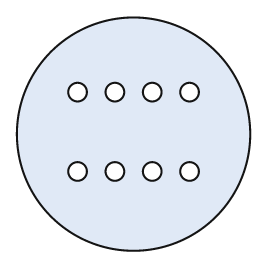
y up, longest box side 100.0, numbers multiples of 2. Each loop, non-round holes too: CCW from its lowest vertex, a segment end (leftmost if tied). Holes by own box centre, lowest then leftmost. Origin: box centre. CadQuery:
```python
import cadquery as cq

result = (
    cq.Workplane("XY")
    .moveTo(0.0, 0.0)
    .circle(50.0)
    .moveTo(-24.0, -16.0)
    .circle(4.0)
    .moveTo(-8.0, -16.0)
    .circle(4.0)
    .moveTo(8.0, -16.0)
    .circle(4.0)
    .moveTo(24.0, -16.0)
    .circle(4.0)
    .moveTo(-24.0, 18.0)
    .circle(4.0)
    .moveTo(-8.0, 18.0)
    .circle(4.0)
    .moveTo(8.0, 18.0)
    .circle(4.0)
    .moveTo(24.0, 18.0)
    .circle(4.0)
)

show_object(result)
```